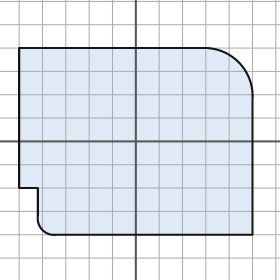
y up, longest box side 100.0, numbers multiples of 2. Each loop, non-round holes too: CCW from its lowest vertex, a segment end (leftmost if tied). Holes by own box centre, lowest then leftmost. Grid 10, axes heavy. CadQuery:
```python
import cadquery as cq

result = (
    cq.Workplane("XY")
    .moveTo(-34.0, -40.0)
    .lineTo(50.0, -40.0)
    .lineTo(50.0, 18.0)
    .threePointArc((44.0, 34.0), (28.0, 40.0))
    .lineTo(-50.0, 40.0)
    .lineTo(-50.0, -20.0)
    .lineTo(-42.0, -20.0)
    .lineTo(-42.0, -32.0)
    .threePointArc((-40.0, -38.0), (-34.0, -40.0))
    .close()
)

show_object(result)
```